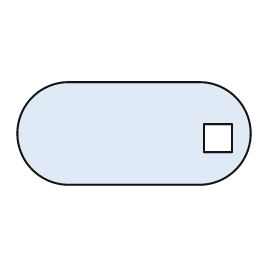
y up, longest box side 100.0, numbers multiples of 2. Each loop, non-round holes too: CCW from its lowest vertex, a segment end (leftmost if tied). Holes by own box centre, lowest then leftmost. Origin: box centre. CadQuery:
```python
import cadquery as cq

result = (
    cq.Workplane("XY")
    .moveTo(-28.0, -22.0)
    .lineTo(28.0, -22.0)
    .threePointArc((50.0, 0.0), (28.0, 22.0))
    .lineTo(-28.0, 22.0)
    .threePointArc((-50.0, 0.0), (-28.0, -22.0))
    .close()
    .moveTo(30.0, -8.0)
    .lineTo(42.0, -8.0)
    .lineTo(42.0, 4.0)
    .lineTo(30.0, 4.0)
    .close()
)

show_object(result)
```